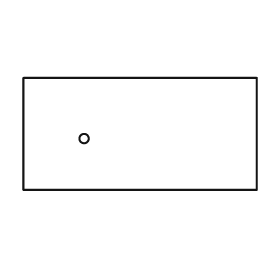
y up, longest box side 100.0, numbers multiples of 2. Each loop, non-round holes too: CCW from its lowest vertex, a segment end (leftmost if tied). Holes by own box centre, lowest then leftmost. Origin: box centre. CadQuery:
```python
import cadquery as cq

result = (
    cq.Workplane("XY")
    .moveTo(-50.0, -24.0)
    .lineTo(50.0, -24.0)
    .lineTo(50.0, 24.0)
    .lineTo(-50.0, 24.0)
    .close()
    .moveTo(-24.0, -2.0)
    .circle(2.0)
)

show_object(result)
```